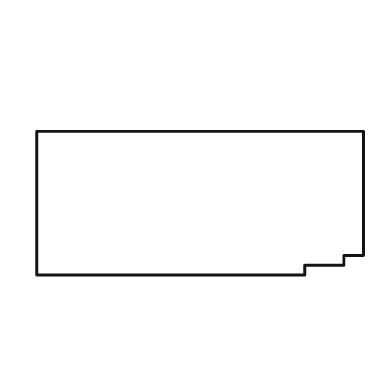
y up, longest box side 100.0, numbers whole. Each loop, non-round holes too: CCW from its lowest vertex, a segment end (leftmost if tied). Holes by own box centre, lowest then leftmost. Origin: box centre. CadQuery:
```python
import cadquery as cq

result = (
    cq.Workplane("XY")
    .moveTo(-50.0, -22.0)
    .lineTo(32.0, -22.0)
    .lineTo(32.0, -19.0)
    .lineTo(44.0, -19.0)
    .lineTo(44.0, -16.0)
    .lineTo(50.0, -16.0)
    .lineTo(50.0, 22.0)
    .lineTo(-50.0, 22.0)
    .close()
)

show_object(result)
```